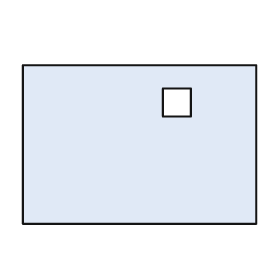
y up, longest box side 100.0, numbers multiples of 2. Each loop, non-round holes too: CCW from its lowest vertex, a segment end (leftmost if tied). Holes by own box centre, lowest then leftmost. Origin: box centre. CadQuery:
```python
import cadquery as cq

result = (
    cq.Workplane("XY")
    .moveTo(-50.0, -34.0)
    .lineTo(50.0, -34.0)
    .lineTo(50.0, 34.0)
    .lineTo(-50.0, 34.0)
    .close()
    .moveTo(10.0, 12.0)
    .lineTo(22.0, 12.0)
    .lineTo(22.0, 24.0)
    .lineTo(10.0, 24.0)
    .close()
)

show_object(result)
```